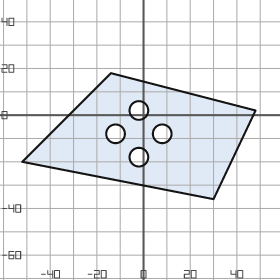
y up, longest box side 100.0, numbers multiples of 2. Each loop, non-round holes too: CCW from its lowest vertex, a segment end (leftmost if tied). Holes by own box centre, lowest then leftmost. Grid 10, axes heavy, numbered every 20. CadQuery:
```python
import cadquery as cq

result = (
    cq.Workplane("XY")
    .moveTo(30.0, -36.0)
    .lineTo(48.0, 2.0)
    .lineTo(-14.0, 18.0)
    .lineTo(-52.0, -20.0)
    .close()
    .moveTo(-2.0, -18.0)
    .circle(4.0)
    .moveTo(-12.0, -8.0)
    .circle(4.0)
    .moveTo(8.0, -8.0)
    .circle(4.0)
    .moveTo(-2.0, 2.0)
    .circle(4.0)
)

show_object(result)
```